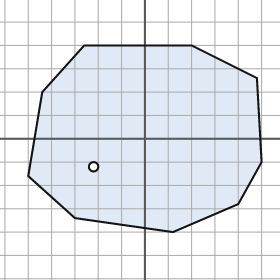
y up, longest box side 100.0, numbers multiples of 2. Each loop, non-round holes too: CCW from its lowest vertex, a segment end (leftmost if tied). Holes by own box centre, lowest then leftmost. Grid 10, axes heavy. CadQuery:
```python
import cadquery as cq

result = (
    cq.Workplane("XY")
    .moveTo(12.0, -40.0)
    .lineTo(40.0, -28.0)
    .lineTo(50.0, -10.0)
    .lineTo(48.0, 26.0)
    .lineTo(20.0, 40.0)
    .lineTo(-26.0, 40.0)
    .lineTo(-44.0, 20.0)
    .lineTo(-50.0, -16.0)
    .lineTo(-30.0, -34.0)
    .close()
    .moveTo(-22.0, -12.0)
    .circle(2.0)
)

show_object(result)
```